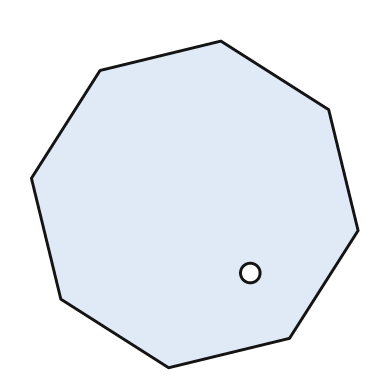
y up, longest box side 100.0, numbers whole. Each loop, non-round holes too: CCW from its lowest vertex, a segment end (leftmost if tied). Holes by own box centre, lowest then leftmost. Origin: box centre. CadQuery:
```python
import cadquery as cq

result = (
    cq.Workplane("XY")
    .moveTo(-8.0, -50.0)
    .lineTo(29.0, -41.0)
    .lineTo(50.0, -8.0)
    .lineTo(41.0, 29.0)
    .lineTo(8.0, 50.0)
    .lineTo(-29.0, 41.0)
    .lineTo(-50.0, 8.0)
    .lineTo(-41.0, -29.0)
    .close()
    .moveTo(17.0, -21.0)
    .circle(3.0)
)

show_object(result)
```